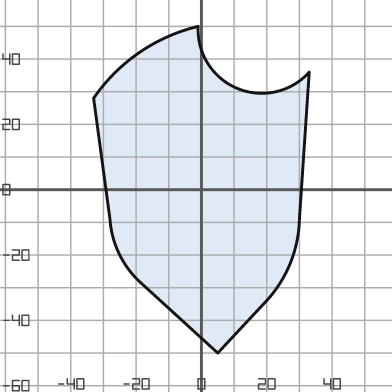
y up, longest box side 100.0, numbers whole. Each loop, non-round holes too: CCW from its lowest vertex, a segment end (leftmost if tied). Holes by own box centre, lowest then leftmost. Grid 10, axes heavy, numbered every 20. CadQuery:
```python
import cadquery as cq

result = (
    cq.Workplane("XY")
    .moveTo(5.0, -50.0)
    .lineTo(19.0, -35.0)
    .threePointArc((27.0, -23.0), (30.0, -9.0))
    .lineTo(33.0, 36.0)
    .threePointArc((11.0, 31.0), (-1.0, 50.0))
    .threePointArc((-19.0, 42.0), (-33.0, 28.0))
    .lineTo(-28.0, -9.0)
    .threePointArc((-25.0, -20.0), (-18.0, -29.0))
    .close()
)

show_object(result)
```